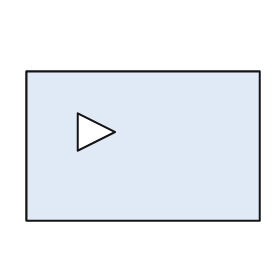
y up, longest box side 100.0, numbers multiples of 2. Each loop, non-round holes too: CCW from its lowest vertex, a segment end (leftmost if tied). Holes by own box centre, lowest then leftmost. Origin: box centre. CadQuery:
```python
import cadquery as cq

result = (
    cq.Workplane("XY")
    .moveTo(-50.0, -32.0)
    .lineTo(50.0, -32.0)
    .lineTo(50.0, 32.0)
    .lineTo(-50.0, 32.0)
    .close()
    .moveTo(-28.0, -2.0)
    .lineTo(-12.0, 6.0)
    .lineTo(-28.0, 14.0)
    .close()
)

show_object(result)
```